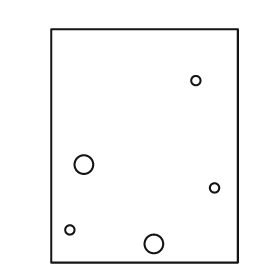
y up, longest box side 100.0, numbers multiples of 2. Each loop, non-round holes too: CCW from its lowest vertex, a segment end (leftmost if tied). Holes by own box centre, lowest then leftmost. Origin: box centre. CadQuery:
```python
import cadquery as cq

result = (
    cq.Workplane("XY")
    .moveTo(-40.0, -50.0)
    .lineTo(40.0, -50.0)
    .lineTo(40.0, 50.0)
    .lineTo(-40.0, 50.0)
    .close()
    .moveTo(4.0, -42.0)
    .circle(4.0)
    .moveTo(-32.0, -36.0)
    .circle(2.0)
    .moveTo(30.0, -18.0)
    .circle(2.0)
    .moveTo(-26.0, -8.0)
    .circle(4.0)
    .moveTo(22.0, 28.0)
    .circle(2.0)
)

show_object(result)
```